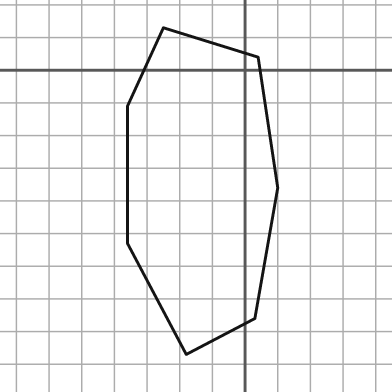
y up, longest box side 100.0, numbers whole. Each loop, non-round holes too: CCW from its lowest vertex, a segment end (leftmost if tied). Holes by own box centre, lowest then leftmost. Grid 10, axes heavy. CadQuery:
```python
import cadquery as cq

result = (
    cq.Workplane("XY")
    .moveTo(-18.0, -87.0)
    .lineTo(3.0, -76.0)
    .lineTo(10.0, -36.0)
    .lineTo(4.0, 4.0)
    .lineTo(-25.0, 13.0)
    .lineTo(-36.0, -11.0)
    .lineTo(-36.0, -53.0)
    .close()
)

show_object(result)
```